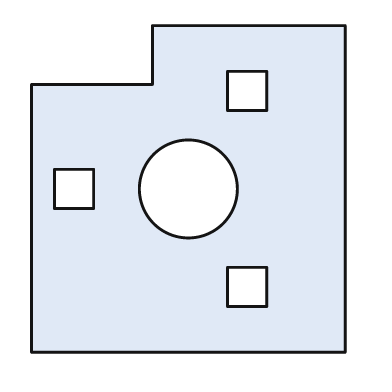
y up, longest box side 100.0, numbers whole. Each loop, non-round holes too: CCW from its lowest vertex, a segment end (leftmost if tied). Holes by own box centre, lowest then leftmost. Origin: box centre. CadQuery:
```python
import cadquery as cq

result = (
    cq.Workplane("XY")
    .moveTo(-48.0, -50.0)
    .lineTo(48.0, -50.0)
    .lineTo(48.0, 50.0)
    .lineTo(-11.0, 50.0)
    .lineTo(-11.0, 32.0)
    .lineTo(-48.0, 32.0)
    .close()
    .moveTo(12.0, -36.0)
    .lineTo(24.0, -36.0)
    .lineTo(24.0, -24.0)
    .lineTo(12.0, -24.0)
    .close()
    .moveTo(-41.0, -6.0)
    .lineTo(-29.0, -6.0)
    .lineTo(-29.0, 6.0)
    .lineTo(-41.0, 6.0)
    .close()
    .moveTo(0.0, 0.0)
    .circle(15.0)
    .moveTo(12.0, 24.0)
    .lineTo(24.0, 24.0)
    .lineTo(24.0, 36.0)
    .lineTo(12.0, 36.0)
    .close()
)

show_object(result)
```